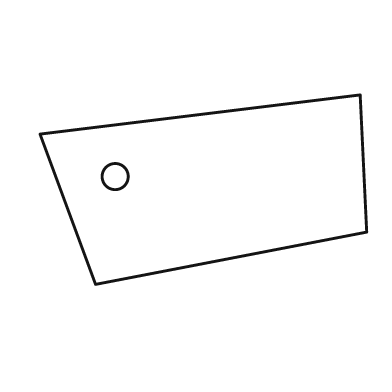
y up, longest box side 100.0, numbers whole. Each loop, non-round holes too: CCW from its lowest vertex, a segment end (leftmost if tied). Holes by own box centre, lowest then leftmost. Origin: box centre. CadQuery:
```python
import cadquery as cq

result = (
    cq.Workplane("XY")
    .moveTo(-33.0, -29.0)
    .lineTo(50.0, -13.0)
    .lineTo(48.0, 29.0)
    .lineTo(-50.0, 17.0)
    .close()
    .moveTo(-27.0, 4.0)
    .circle(4.0)
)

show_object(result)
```